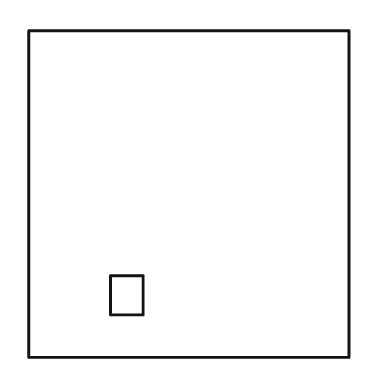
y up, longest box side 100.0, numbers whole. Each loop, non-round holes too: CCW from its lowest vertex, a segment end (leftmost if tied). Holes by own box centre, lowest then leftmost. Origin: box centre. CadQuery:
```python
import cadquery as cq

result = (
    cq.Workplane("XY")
    .moveTo(-49.0, -50.0)
    .lineTo(49.0, -50.0)
    .lineTo(49.0, 50.0)
    .lineTo(-49.0, 50.0)
    .close()
    .moveTo(-24.0, -37.0)
    .lineTo(-14.0, -37.0)
    .lineTo(-14.0, -25.0)
    .lineTo(-24.0, -25.0)
    .close()
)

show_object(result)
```